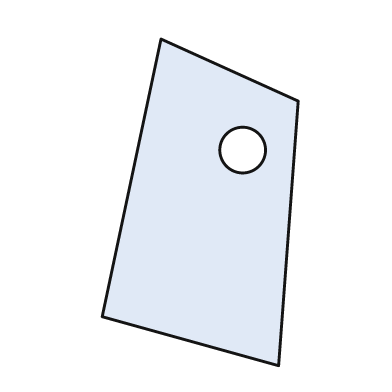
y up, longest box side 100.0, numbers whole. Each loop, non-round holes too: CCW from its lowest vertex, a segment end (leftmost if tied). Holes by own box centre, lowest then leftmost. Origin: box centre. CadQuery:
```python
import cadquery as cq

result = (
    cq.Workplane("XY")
    .moveTo(24.0, -50.0)
    .lineTo(30.0, 31.0)
    .lineTo(-12.0, 50.0)
    .lineTo(-30.0, -35.0)
    .close()
    .moveTo(13.0, 16.0)
    .circle(7.0)
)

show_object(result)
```